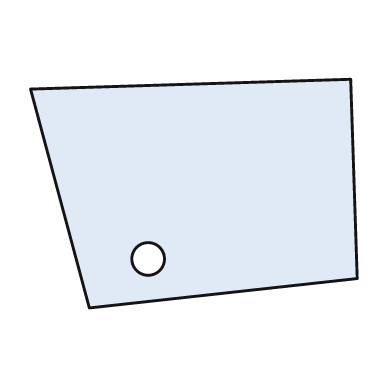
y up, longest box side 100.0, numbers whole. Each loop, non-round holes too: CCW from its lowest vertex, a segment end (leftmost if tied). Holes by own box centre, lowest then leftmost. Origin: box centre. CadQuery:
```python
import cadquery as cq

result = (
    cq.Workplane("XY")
    .moveTo(-32.0, -35.0)
    .lineTo(50.0, -26.0)
    .lineTo(48.0, 35.0)
    .lineTo(-50.0, 32.0)
    .close()
    .moveTo(-14.0, -20.0)
    .circle(5.0)
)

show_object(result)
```